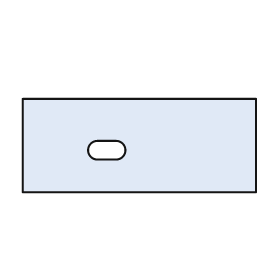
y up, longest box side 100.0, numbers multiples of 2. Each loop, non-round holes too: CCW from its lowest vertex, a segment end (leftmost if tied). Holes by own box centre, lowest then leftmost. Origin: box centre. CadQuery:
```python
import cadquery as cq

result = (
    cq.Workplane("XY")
    .moveTo(-50.0, -20.0)
    .lineTo(50.0, -20.0)
    .lineTo(50.0, 20.0)
    .lineTo(-50.0, 20.0)
    .close()
    .moveTo(-18.0, -6.0)
    .lineTo(-10.0, -6.0)
    .threePointArc((-6.0, -2.0), (-10.0, 2.0))
    .lineTo(-18.0, 2.0)
    .threePointArc((-22.0, -2.0), (-18.0, -6.0))
    .close()
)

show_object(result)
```